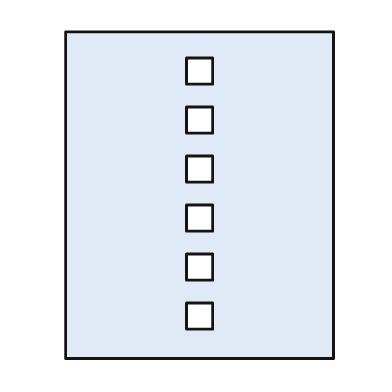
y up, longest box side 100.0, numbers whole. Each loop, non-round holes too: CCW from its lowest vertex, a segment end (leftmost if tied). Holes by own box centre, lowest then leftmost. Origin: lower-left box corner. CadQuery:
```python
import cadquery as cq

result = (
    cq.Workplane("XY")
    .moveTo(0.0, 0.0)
    .lineTo(82.0, 0.0)
    .lineTo(82.0, 100.0)
    .lineTo(0.0, 100.0)
    .close()
    .moveTo(37.0, 9.0)
    .lineTo(45.0, 9.0)
    .lineTo(45.0, 17.0)
    .lineTo(37.0, 17.0)
    .close()
    .moveTo(37.0, 24.0)
    .lineTo(45.0, 24.0)
    .lineTo(45.0, 32.0)
    .lineTo(37.0, 32.0)
    .close()
    .moveTo(37.0, 39.0)
    .lineTo(45.0, 39.0)
    .lineTo(45.0, 47.0)
    .lineTo(37.0, 47.0)
    .close()
    .moveTo(37.0, 54.0)
    .lineTo(45.0, 54.0)
    .lineTo(45.0, 62.0)
    .lineTo(37.0, 62.0)
    .close()
    .moveTo(37.0, 69.0)
    .lineTo(45.0, 69.0)
    .lineTo(45.0, 77.0)
    .lineTo(37.0, 77.0)
    .close()
    .moveTo(37.0, 84.0)
    .lineTo(45.0, 84.0)
    .lineTo(45.0, 92.0)
    .lineTo(37.0, 92.0)
    .close()
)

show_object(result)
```